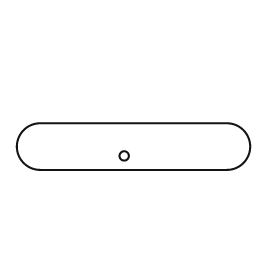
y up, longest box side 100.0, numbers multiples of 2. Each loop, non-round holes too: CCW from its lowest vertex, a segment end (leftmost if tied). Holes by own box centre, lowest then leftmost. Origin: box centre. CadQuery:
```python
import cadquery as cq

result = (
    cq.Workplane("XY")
    .moveTo(-40.0, -10.0)
    .lineTo(40.0, -10.0)
    .threePointArc((50.0, 0.0), (40.0, 10.0))
    .lineTo(-40.0, 10.0)
    .threePointArc((-50.0, 0.0), (-40.0, -10.0))
    .close()
    .moveTo(-4.0, -4.0)
    .circle(2.0)
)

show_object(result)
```